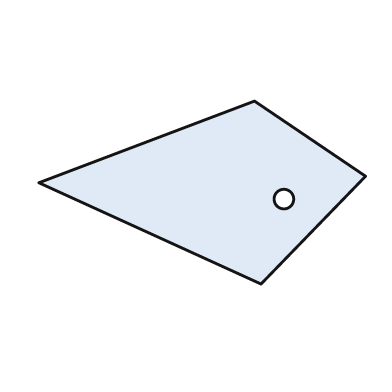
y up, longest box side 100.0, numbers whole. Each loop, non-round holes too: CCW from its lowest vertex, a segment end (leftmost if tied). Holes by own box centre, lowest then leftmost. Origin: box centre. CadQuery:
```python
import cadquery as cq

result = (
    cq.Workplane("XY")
    .moveTo(18.0, -28.0)
    .lineTo(50.0, 5.0)
    .lineTo(16.0, 28.0)
    .lineTo(-50.0, 3.0)
    .close()
    .moveTo(25.0, -2.0)
    .circle(3.0)
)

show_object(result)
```